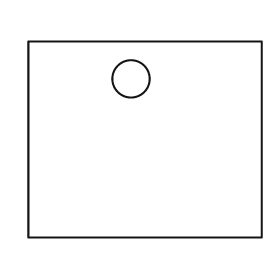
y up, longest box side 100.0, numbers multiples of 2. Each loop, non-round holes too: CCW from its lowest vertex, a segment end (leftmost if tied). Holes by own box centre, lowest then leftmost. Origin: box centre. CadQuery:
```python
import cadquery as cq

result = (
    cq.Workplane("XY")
    .moveTo(-50.0, -42.0)
    .lineTo(50.0, -42.0)
    .lineTo(50.0, 42.0)
    .lineTo(-50.0, 42.0)
    .close()
    .moveTo(-6.0, 26.0)
    .circle(8.0)
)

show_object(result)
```